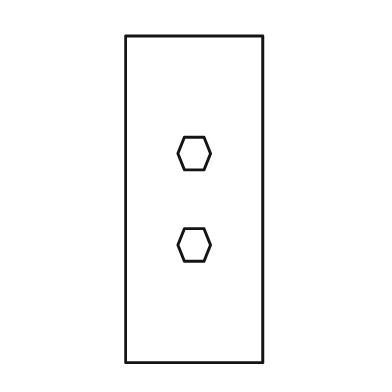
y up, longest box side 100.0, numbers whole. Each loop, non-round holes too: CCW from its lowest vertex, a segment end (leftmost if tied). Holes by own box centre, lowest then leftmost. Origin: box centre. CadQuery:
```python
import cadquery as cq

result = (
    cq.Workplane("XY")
    .moveTo(-21.0, -50.0)
    .lineTo(21.0, -50.0)
    .lineTo(21.0, 50.0)
    .lineTo(-21.0, 50.0)
    .close()
    .moveTo(-3.0, -19.0)
    .lineTo(3.0, -19.0)
    .lineTo(5.0, -14.0)
    .lineTo(3.0, -9.0)
    .lineTo(-3.0, -9.0)
    .lineTo(-5.0, -14.0)
    .close()
    .moveTo(-3.0, 9.0)
    .lineTo(3.0, 9.0)
    .lineTo(5.0, 14.0)
    .lineTo(3.0, 19.0)
    .lineTo(-3.0, 19.0)
    .lineTo(-5.0, 14.0)
    .close()
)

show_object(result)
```